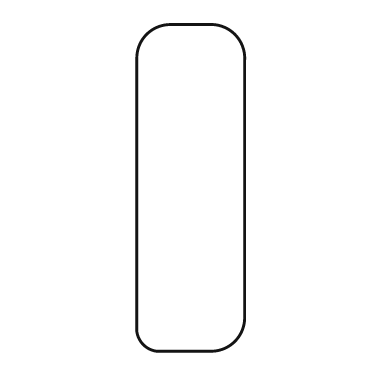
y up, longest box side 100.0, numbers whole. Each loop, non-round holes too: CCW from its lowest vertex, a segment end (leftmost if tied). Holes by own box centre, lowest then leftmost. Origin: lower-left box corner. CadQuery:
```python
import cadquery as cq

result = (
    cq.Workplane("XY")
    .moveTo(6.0, 0.0)
    .lineTo(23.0, 0.0)
    .threePointArc((30.0, 3.0), (33.0, 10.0))
    .lineTo(33.0, 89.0)
    .threePointArc((30.0, 97.0), (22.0, 100.0))
    .lineTo(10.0, 100.0)
    .threePointArc((3.0, 97.0), (0.0, 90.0))
    .lineTo(0.0, 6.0)
    .threePointArc((2.0, 2.0), (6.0, 0.0))
    .close()
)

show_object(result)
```